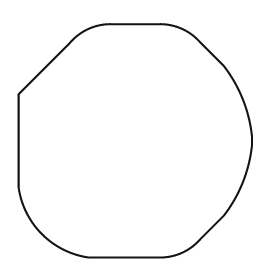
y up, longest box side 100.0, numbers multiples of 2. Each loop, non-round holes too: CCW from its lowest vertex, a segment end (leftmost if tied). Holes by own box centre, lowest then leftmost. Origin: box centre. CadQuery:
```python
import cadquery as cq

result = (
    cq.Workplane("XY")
    .moveTo(-20.0, -50.0)
    .lineTo(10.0, -50.0)
    .threePointArc((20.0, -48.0), (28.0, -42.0))
    .lineTo(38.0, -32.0)
    .threePointArc((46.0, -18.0), (50.0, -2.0))
    .lineTo(50.0, 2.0)
    .threePointArc((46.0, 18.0), (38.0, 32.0))
    .lineTo(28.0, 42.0)
    .threePointArc((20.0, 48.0), (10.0, 50.0))
    .lineTo(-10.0, 50.0)
    .threePointArc((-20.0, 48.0), (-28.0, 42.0))
    .lineTo(-50.0, 20.0)
    .lineTo(-50.0, -20.0)
    .threePointArc((-40.0, -40.0), (-20.0, -50.0))
    .close()
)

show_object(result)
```